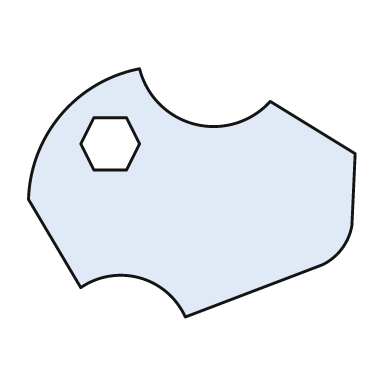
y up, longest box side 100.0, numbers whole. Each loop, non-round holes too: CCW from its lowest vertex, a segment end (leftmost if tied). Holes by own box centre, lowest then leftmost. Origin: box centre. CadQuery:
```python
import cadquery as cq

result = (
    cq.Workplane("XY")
    .moveTo(-2.0, -38.0)
    .lineTo(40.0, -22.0)
    .threePointArc((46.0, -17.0), (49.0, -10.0))
    .lineTo(50.0, 12.0)
    .lineTo(24.0, 28.0)
    .threePointArc((1.0, 21.0), (-16.0, 38.0))
    .threePointArc((-40.0, 24.0), (-50.0, -2.0))
    .lineTo(-34.0, -29.0)
    .threePointArc((-16.0, -26.0), (-2.0, -38.0))
    .close()
    .moveTo(-30.0, 7.0)
    .lineTo(-20.0, 7.0)
    .lineTo(-16.0, 15.0)
    .lineTo(-20.0, 23.0)
    .lineTo(-30.0, 23.0)
    .lineTo(-34.0, 15.0)
    .close()
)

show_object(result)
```